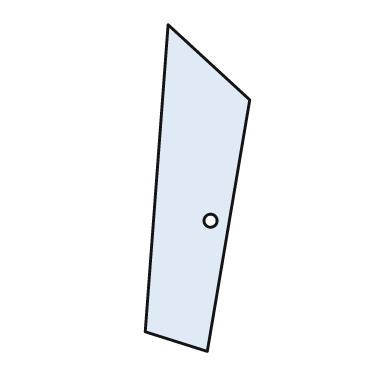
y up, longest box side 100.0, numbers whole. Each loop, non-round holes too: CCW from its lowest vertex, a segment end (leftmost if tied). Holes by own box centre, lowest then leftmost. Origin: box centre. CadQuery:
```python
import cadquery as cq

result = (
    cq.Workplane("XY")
    .moveTo(3.0, -50.0)
    .lineTo(16.0, 27.0)
    .lineTo(-9.0, 50.0)
    .lineTo(-16.0, -44.0)
    .close()
    .moveTo(4.0, -10.0)
    .circle(2.0)
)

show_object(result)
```